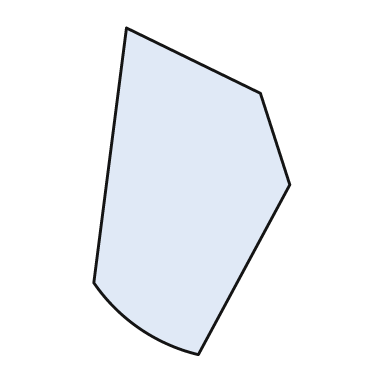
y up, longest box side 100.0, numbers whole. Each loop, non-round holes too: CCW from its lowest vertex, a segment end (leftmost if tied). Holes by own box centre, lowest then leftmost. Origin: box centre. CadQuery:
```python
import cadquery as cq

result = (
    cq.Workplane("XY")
    .moveTo(2.0, -50.0)
    .lineTo(30.0, 2.0)
    .lineTo(21.0, 30.0)
    .lineTo(-20.0, 50.0)
    .lineTo(-30.0, -28.0)
    .threePointArc((-16.0, -42.0), (2.0, -50.0))
    .close()
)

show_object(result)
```